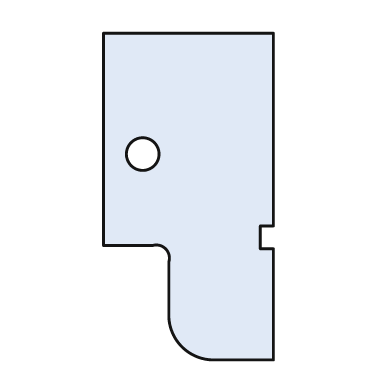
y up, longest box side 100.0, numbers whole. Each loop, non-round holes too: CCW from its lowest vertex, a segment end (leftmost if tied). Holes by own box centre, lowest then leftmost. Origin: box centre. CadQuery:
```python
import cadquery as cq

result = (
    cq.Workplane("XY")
    .moveTo(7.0, -50.0)
    .lineTo(26.0, -50.0)
    .lineTo(26.0, -16.0)
    .lineTo(22.0, -16.0)
    .lineTo(22.0, -9.0)
    .lineTo(26.0, -9.0)
    .lineTo(26.0, 50.0)
    .lineTo(-26.0, 50.0)
    .lineTo(-26.0, -15.0)
    .lineTo(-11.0, -15.0)
    .threePointArc((-7.0, -16.0), (-6.0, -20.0))
    .lineTo(-6.0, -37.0)
    .threePointArc((-2.0, -46.0), (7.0, -50.0))
    .close()
    .moveTo(-14.0, 13.0)
    .circle(5.0)
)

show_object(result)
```